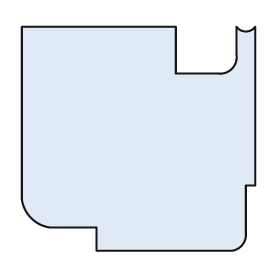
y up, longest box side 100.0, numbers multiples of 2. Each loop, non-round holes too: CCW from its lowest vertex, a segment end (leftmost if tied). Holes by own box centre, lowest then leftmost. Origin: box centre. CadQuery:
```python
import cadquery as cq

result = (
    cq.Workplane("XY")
    .moveTo(-18.0, -48.0)
    .lineTo(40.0, -48.0)
    .threePointArc((44.0, -46.0), (46.0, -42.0))
    .lineTo(46.0, -20.0)
    .lineTo(50.0, -20.0)
    .lineTo(50.0, 48.0)
    .threePointArc((46.0, 46.0), (42.0, 48.0))
    .lineTo(42.0, 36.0)
    .threePointArc((40.0, 30.0), (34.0, 28.0))
    .lineTo(16.0, 28.0)
    .lineTo(16.0, 48.0)
    .lineTo(-50.0, 48.0)
    .lineTo(-50.0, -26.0)
    .threePointArc((-46.0, -34.0), (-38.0, -38.0))
    .lineTo(-18.0, -38.0)
    .close()
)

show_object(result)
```